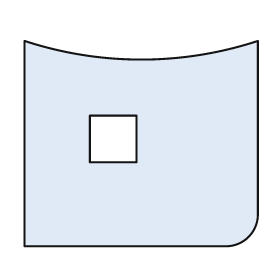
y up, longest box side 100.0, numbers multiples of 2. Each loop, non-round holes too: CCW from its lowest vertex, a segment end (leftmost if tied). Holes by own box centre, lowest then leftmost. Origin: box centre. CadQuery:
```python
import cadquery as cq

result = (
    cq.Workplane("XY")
    .moveTo(-50.0, -44.0)
    .lineTo(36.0, -44.0)
    .threePointArc((46.0, -40.0), (50.0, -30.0))
    .lineTo(50.0, 44.0)
    .threePointArc((0.0, 36.0), (-50.0, 44.0))
    .close()
    .moveTo(-22.0, -8.0)
    .lineTo(-2.0, -8.0)
    .lineTo(-2.0, 12.0)
    .lineTo(-22.0, 12.0)
    .close()
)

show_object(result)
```